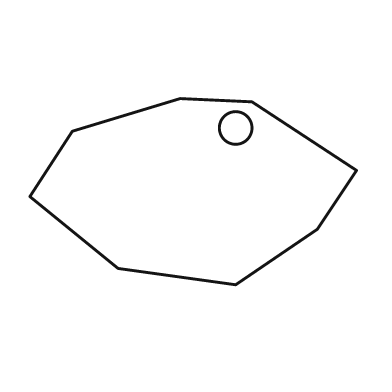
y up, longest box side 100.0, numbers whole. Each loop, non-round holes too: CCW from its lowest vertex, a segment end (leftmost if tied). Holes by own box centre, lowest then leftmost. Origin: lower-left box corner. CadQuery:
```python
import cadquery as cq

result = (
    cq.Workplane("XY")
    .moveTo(63.0, 0.0)
    .lineTo(88.0, 17.0)
    .lineTo(100.0, 35.0)
    .lineTo(68.0, 56.0)
    .lineTo(46.0, 57.0)
    .lineTo(13.0, 47.0)
    .lineTo(0.0, 27.0)
    .lineTo(27.0, 5.0)
    .close()
    .moveTo(63.0, 48.0)
    .circle(5.0)
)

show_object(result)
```